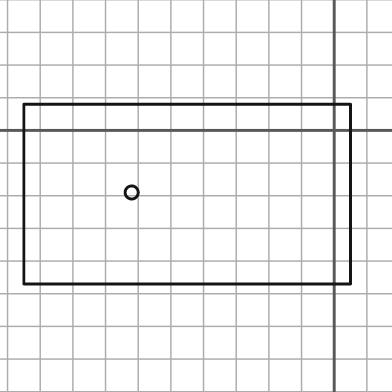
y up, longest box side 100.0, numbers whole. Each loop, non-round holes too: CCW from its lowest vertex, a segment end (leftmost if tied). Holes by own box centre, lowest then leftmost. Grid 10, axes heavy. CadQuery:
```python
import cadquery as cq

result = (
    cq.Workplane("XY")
    .moveTo(-95.0, -47.0)
    .lineTo(5.0, -47.0)
    .lineTo(5.0, 8.0)
    .lineTo(-95.0, 8.0)
    .close()
    .moveTo(-62.0, -19.0)
    .circle(2.0)
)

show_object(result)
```